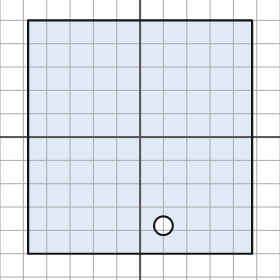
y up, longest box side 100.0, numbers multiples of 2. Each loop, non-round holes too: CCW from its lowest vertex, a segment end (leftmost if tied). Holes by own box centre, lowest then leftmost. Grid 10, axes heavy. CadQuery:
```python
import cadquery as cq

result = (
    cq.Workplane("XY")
    .moveTo(-48.0, -50.0)
    .lineTo(48.0, -50.0)
    .lineTo(48.0, 50.0)
    .lineTo(-48.0, 50.0)
    .close()
    .moveTo(10.0, -38.0)
    .circle(4.0)
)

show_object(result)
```